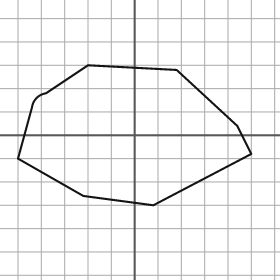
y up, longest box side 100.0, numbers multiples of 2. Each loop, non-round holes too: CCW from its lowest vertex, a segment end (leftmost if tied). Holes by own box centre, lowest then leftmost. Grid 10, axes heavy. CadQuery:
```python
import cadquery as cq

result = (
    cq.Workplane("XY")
    .moveTo(8.0, -30.0)
    .lineTo(50.0, -8.0)
    .lineTo(44.0, 4.0)
    .lineTo(18.0, 28.0)
    .lineTo(-20.0, 30.0)
    .lineTo(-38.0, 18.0)
    .threePointArc((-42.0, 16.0), (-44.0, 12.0))
    .lineTo(-50.0, -10.0)
    .lineTo(-22.0, -26.0)
    .close()
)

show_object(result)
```